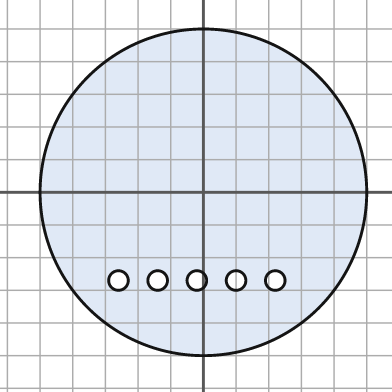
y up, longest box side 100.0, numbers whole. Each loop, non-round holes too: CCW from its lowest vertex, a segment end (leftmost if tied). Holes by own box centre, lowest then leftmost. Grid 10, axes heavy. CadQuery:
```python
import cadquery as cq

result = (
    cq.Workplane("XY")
    .moveTo(0.0, 0.0)
    .circle(50.0)
    .moveTo(-26.0, -27.0)
    .circle(3.0)
    .moveTo(-14.0, -27.0)
    .circle(3.0)
    .moveTo(-2.0, -27.0)
    .circle(3.0)
    .moveTo(10.0, -27.0)
    .circle(3.0)
    .moveTo(22.0, -27.0)
    .circle(3.0)
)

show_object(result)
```